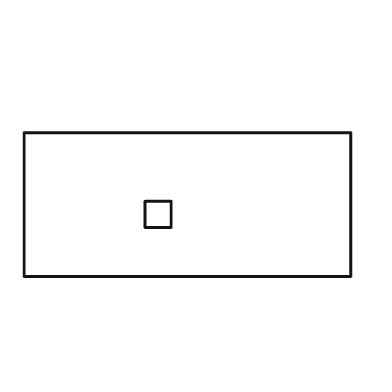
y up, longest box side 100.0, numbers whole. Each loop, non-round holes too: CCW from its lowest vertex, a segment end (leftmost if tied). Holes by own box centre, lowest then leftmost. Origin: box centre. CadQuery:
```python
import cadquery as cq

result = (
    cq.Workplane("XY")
    .moveTo(-50.0, -22.0)
    .lineTo(50.0, -22.0)
    .lineTo(50.0, 22.0)
    .lineTo(-50.0, 22.0)
    .close()
    .moveTo(-13.0, -7.0)
    .lineTo(-5.0, -7.0)
    .lineTo(-5.0, 1.0)
    .lineTo(-13.0, 1.0)
    .close()
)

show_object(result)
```